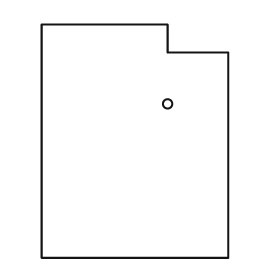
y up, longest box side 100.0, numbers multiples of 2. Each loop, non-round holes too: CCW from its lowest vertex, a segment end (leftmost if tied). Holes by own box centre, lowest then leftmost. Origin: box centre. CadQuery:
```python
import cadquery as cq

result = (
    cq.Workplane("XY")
    .moveTo(-40.0, -50.0)
    .lineTo(40.0, -50.0)
    .lineTo(40.0, 38.0)
    .lineTo(14.0, 38.0)
    .lineTo(14.0, 50.0)
    .lineTo(-40.0, 50.0)
    .close()
    .moveTo(14.0, 16.0)
    .circle(2.0)
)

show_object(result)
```